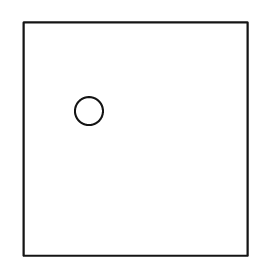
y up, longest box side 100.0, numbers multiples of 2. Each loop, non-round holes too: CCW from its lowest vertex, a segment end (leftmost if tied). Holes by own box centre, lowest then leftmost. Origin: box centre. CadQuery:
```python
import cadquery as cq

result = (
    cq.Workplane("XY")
    .moveTo(-48.0, -50.0)
    .lineTo(48.0, -50.0)
    .lineTo(48.0, 50.0)
    .lineTo(-48.0, 50.0)
    .close()
    .moveTo(-20.0, 12.0)
    .circle(6.0)
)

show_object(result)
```